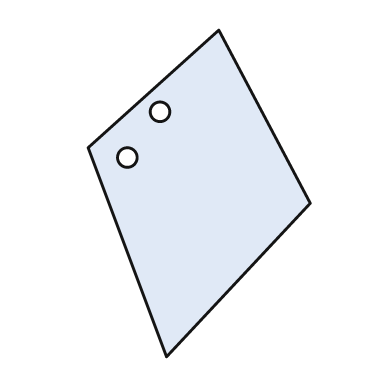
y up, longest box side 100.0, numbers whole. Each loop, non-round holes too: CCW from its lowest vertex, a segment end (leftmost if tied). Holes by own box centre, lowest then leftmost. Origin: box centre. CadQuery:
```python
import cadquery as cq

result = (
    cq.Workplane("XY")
    .moveTo(-10.0, -50.0)
    .lineTo(34.0, -3.0)
    .lineTo(6.0, 50.0)
    .lineTo(-34.0, 14.0)
    .close()
    .moveTo(-22.0, 11.0)
    .circle(3.0)
    .moveTo(-12.0, 25.0)
    .circle(3.0)
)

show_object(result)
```